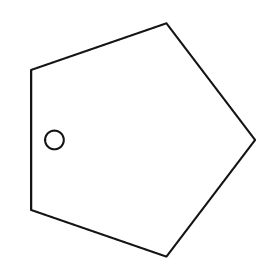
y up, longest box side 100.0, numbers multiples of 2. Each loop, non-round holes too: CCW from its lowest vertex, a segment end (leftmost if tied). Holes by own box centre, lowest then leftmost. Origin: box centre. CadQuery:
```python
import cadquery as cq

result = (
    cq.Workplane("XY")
    .moveTo(10.0, -50.0)
    .lineTo(48.0, 0.0)
    .lineTo(10.0, 50.0)
    .lineTo(-48.0, 30.0)
    .lineTo(-48.0, -30.0)
    .close()
    .moveTo(-38.0, 0.0)
    .circle(4.0)
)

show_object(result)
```